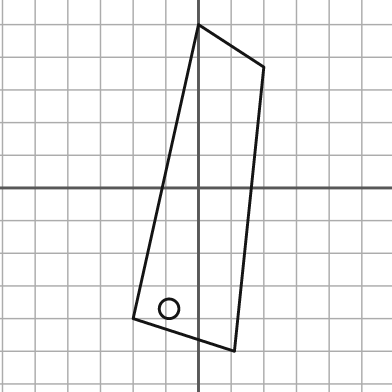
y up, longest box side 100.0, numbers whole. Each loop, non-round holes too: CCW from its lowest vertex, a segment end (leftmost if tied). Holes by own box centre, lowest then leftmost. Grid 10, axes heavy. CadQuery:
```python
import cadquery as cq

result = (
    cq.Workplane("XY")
    .moveTo(11.0, -50.0)
    .lineTo(20.0, 37.0)
    .lineTo(0.0, 50.0)
    .lineTo(-20.0, -40.0)
    .close()
    .moveTo(-9.0, -37.0)
    .circle(3.0)
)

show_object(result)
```